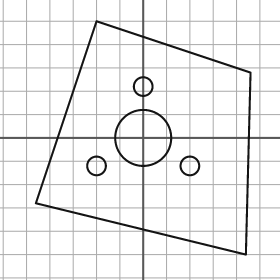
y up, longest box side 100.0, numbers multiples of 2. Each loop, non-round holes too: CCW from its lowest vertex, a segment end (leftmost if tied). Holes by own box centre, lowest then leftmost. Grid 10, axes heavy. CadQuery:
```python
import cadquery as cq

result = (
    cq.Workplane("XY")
    .moveTo(44.0, -50.0)
    .lineTo(46.0, 28.0)
    .lineTo(-20.0, 50.0)
    .lineTo(-46.0, -28.0)
    .close()
    .moveTo(-20.0, -12.0)
    .circle(4.0)
    .moveTo(20.0, -12.0)
    .circle(4.0)
    .moveTo(0.0, 0.0)
    .circle(12.0)
    .moveTo(0.0, 22.0)
    .circle(4.0)
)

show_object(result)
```